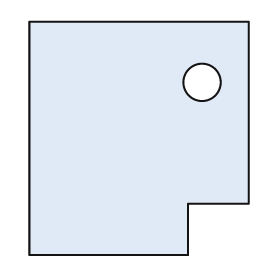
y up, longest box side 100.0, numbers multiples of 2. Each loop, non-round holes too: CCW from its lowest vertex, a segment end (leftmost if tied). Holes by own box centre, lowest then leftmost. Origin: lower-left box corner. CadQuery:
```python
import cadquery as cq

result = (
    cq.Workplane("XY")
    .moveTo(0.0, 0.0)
    .lineTo(68.0, 0.0)
    .lineTo(68.0, 22.0)
    .lineTo(94.0, 22.0)
    .lineTo(94.0, 100.0)
    .lineTo(0.0, 100.0)
    .close()
    .moveTo(74.0, 74.0)
    .circle(8.0)
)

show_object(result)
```